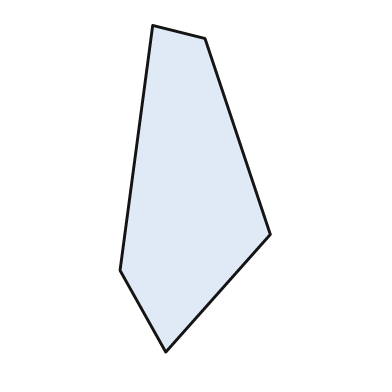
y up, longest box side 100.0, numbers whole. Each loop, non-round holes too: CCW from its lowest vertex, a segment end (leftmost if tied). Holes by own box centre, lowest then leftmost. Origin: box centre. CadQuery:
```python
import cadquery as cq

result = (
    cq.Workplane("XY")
    .moveTo(-9.0, -50.0)
    .lineTo(23.0, -14.0)
    .lineTo(3.0, 46.0)
    .lineTo(-13.0, 50.0)
    .lineTo(-23.0, -25.0)
    .close()
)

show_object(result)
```